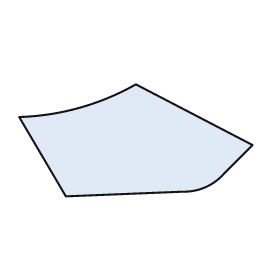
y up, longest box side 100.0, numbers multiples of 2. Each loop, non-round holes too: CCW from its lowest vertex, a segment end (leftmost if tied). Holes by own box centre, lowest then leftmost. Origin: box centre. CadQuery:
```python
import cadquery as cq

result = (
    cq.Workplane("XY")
    .moveTo(-30.0, -24.0)
    .lineTo(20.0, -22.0)
    .threePointArc((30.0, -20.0), (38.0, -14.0))
    .lineTo(50.0, -2.0)
    .lineTo(0.0, 24.0)
    .threePointArc((-24.0, 14.0), (-50.0, 10.0))
    .close()
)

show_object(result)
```